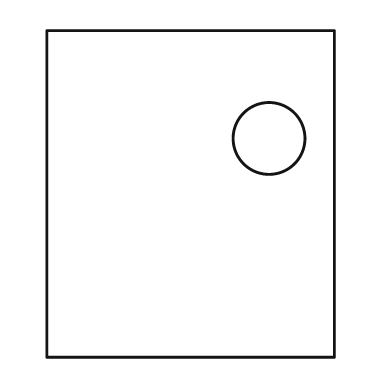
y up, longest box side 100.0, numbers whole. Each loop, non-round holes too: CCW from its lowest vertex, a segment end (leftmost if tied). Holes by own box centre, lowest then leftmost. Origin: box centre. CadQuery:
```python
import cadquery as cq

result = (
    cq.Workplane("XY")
    .moveTo(-44.0, -50.0)
    .lineTo(44.0, -50.0)
    .lineTo(44.0, 50.0)
    .lineTo(-44.0, 50.0)
    .close()
    .moveTo(24.0, 17.0)
    .circle(11.0)
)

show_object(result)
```